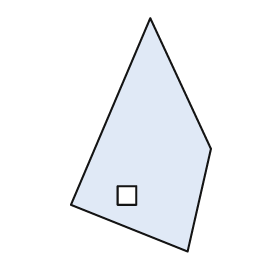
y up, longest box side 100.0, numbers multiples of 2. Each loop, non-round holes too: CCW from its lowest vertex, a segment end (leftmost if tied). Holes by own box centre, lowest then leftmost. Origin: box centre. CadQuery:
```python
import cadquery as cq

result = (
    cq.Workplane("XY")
    .moveTo(20.0, -50.0)
    .lineTo(30.0, -6.0)
    .lineTo(4.0, 50.0)
    .lineTo(-30.0, -30.0)
    .close()
    .moveTo(-10.0, -30.0)
    .lineTo(-2.0, -30.0)
    .lineTo(-2.0, -22.0)
    .lineTo(-10.0, -22.0)
    .close()
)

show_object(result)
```